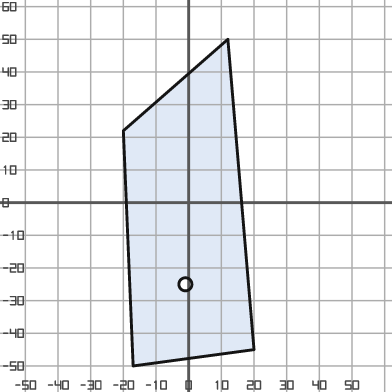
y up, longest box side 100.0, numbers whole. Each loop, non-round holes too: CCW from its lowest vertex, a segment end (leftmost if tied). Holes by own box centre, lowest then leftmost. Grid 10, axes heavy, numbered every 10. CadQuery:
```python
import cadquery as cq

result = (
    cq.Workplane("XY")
    .moveTo(-17.0, -50.0)
    .lineTo(20.0, -45.0)
    .lineTo(12.0, 50.0)
    .lineTo(-20.0, 22.0)
    .close()
    .moveTo(-1.0, -25.0)
    .circle(2.0)
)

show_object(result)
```